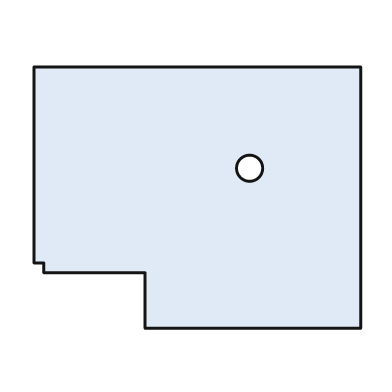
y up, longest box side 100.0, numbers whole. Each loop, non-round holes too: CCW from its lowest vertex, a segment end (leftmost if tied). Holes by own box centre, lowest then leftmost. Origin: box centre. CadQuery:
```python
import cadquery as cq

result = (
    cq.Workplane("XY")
    .moveTo(-16.0, -40.0)
    .lineTo(50.0, -40.0)
    .lineTo(50.0, 40.0)
    .lineTo(-50.0, 40.0)
    .lineTo(-50.0, -20.0)
    .lineTo(-47.0, -20.0)
    .lineTo(-47.0, -23.0)
    .lineTo(-16.0, -23.0)
    .close()
    .moveTo(16.0, 9.0)
    .circle(4.0)
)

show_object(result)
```